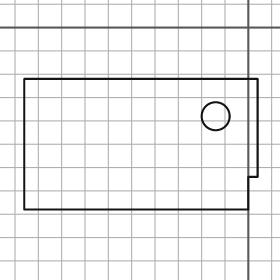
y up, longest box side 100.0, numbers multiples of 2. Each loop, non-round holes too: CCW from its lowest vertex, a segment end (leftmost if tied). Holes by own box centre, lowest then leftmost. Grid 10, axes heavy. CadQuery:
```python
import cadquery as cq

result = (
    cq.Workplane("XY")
    .moveTo(-96.0, -78.0)
    .lineTo(0.0, -78.0)
    .lineTo(0.0, -64.0)
    .lineTo(4.0, -64.0)
    .lineTo(4.0, -22.0)
    .lineTo(-96.0, -22.0)
    .close()
    .moveTo(-14.0, -38.0)
    .circle(6.0)
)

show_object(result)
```